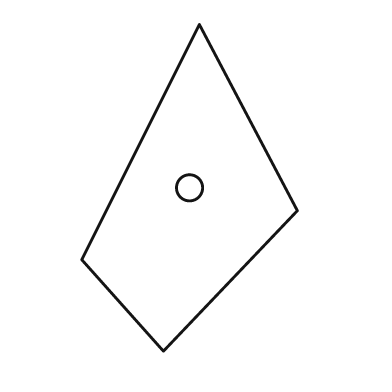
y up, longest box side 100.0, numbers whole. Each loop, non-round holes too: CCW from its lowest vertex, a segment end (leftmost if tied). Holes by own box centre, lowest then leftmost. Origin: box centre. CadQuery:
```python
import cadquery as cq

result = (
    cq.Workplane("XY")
    .moveTo(-8.0, -50.0)
    .lineTo(33.0, -7.0)
    .lineTo(3.0, 50.0)
    .lineTo(-33.0, -22.0)
    .close()
    .moveTo(0.0, 0.0)
    .circle(4.0)
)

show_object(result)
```